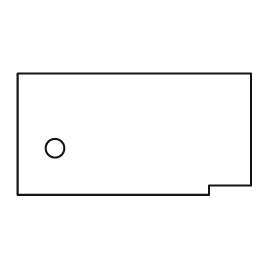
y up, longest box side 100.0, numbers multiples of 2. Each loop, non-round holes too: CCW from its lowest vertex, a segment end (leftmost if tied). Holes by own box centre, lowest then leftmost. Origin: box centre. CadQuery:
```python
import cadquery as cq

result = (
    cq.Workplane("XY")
    .moveTo(-50.0, -26.0)
    .lineTo(32.0, -26.0)
    .lineTo(32.0, -22.0)
    .lineTo(50.0, -22.0)
    .lineTo(50.0, 26.0)
    .lineTo(-50.0, 26.0)
    .close()
    .moveTo(-34.0, -6.0)
    .circle(4.0)
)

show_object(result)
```